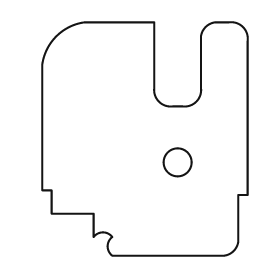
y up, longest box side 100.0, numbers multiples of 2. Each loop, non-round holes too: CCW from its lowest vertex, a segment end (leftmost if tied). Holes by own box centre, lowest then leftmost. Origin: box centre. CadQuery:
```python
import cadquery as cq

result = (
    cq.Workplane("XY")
    .moveTo(-14.0, -50.0)
    .lineTo(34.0, -50.0)
    .threePointArc((38.0, -48.0), (40.0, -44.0))
    .lineTo(40.0, -24.0)
    .lineTo(44.0, -24.0)
    .lineTo(44.0, 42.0)
    .threePointArc((42.0, 48.0), (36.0, 50.0))
    .lineTo(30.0, 50.0)
    .threePointArc((26.0, 48.0), (24.0, 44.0))
    .lineTo(24.0, 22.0)
    .threePointArc((22.0, 16.0), (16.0, 14.0))
    .lineTo(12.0, 14.0)
    .threePointArc((6.0, 16.0), (4.0, 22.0))
    .lineTo(4.0, 50.0)
    .lineTo(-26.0, 50.0)
    .threePointArc((-38.0, 44.0), (-44.0, 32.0))
    .lineTo(-44.0, -22.0)
    .lineTo(-40.0, -22.0)
    .lineTo(-40.0, -32.0)
    .lineTo(-22.0, -32.0)
    .lineTo(-22.0, -42.0)
    .threePointArc((-18.0, -40.0), (-14.0, -42.0))
    .threePointArc((-16.0, -46.0), (-14.0, -50.0))
    .close()
    .moveTo(14.0, -10.0)
    .circle(6.0)
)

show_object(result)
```